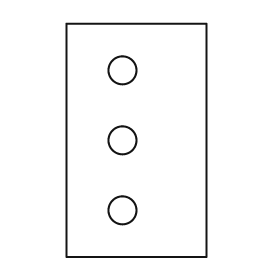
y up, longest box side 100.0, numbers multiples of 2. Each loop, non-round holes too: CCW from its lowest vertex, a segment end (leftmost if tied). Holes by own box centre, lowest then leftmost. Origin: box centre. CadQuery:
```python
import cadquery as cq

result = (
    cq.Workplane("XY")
    .moveTo(-30.0, -50.0)
    .lineTo(30.0, -50.0)
    .lineTo(30.0, 50.0)
    .lineTo(-30.0, 50.0)
    .close()
    .moveTo(-6.0, -30.0)
    .circle(6.0)
    .moveTo(-6.0, 0.0)
    .circle(6.0)
    .moveTo(-6.0, 30.0)
    .circle(6.0)
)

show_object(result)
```